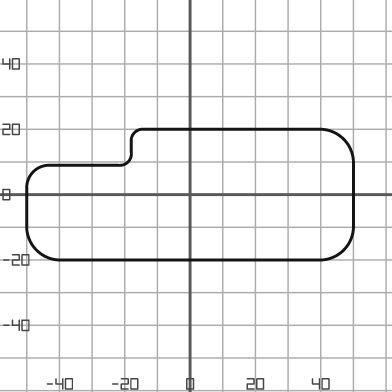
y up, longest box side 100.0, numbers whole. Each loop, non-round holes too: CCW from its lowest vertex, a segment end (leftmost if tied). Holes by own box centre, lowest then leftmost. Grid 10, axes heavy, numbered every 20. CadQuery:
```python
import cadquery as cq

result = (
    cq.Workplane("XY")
    .moveTo(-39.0, -20.0)
    .lineTo(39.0, -20.0)
    .threePointArc((47.0, -17.0), (50.0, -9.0))
    .lineTo(50.0, 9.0)
    .threePointArc((47.0, 17.0), (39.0, 20.0))
    .lineTo(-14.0, 20.0)
    .threePointArc((-17.0, 19.0), (-18.0, 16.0))
    .lineTo(-18.0, 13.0)
    .threePointArc((-19.0, 10.0), (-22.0, 9.0))
    .lineTo(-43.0, 9.0)
    .threePointArc((-48.0, 7.0), (-50.0, 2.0))
    .lineTo(-50.0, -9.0)
    .threePointArc((-47.0, -17.0), (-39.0, -20.0))
    .close()
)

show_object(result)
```